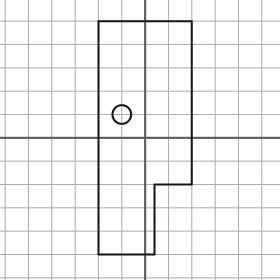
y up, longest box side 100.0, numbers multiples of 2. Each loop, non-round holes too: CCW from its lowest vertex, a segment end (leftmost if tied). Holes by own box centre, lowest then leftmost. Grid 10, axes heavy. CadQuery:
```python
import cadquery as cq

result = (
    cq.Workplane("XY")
    .moveTo(-20.0, -50.0)
    .lineTo(4.0, -50.0)
    .lineTo(4.0, -20.0)
    .lineTo(20.0, -20.0)
    .lineTo(20.0, 50.0)
    .lineTo(-20.0, 50.0)
    .close()
    .moveTo(-10.0, 10.0)
    .circle(4.0)
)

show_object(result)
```